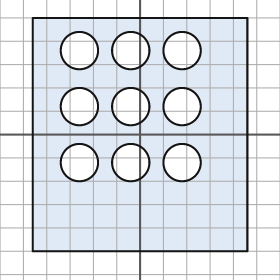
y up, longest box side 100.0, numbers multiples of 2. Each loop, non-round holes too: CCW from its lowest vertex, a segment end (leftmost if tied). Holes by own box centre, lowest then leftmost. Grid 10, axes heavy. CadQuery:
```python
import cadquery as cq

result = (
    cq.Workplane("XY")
    .moveTo(-46.0, -50.0)
    .lineTo(46.0, -50.0)
    .lineTo(46.0, 50.0)
    .lineTo(-46.0, 50.0)
    .close()
    .moveTo(-26.0, -12.0)
    .circle(8.0)
    .moveTo(-4.0, -12.0)
    .circle(8.0)
    .moveTo(18.0, -12.0)
    .circle(8.0)
    .moveTo(-26.0, 12.0)
    .circle(8.0)
    .moveTo(-4.0, 12.0)
    .circle(8.0)
    .moveTo(18.0, 12.0)
    .circle(8.0)
    .moveTo(-26.0, 36.0)
    .circle(8.0)
    .moveTo(-4.0, 36.0)
    .circle(8.0)
    .moveTo(18.0, 36.0)
    .circle(8.0)
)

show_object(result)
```